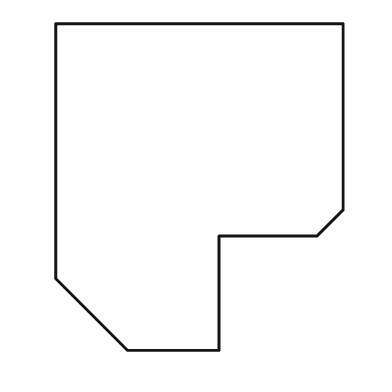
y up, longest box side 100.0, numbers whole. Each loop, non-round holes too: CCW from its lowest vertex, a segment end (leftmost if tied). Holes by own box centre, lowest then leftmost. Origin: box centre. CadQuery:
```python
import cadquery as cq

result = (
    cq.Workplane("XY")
    .moveTo(-22.0, -50.0)
    .lineTo(6.0, -50.0)
    .lineTo(6.0, -15.0)
    .lineTo(36.0, -15.0)
    .lineTo(44.0, -7.0)
    .lineTo(44.0, 50.0)
    .lineTo(-44.0, 50.0)
    .lineTo(-44.0, -28.0)
    .close()
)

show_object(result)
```